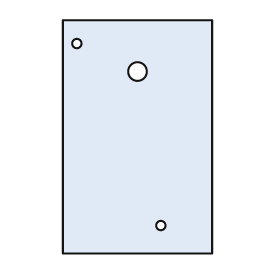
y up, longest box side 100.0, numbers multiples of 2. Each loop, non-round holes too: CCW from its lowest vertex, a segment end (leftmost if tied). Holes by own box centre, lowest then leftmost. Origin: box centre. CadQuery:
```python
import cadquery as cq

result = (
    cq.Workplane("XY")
    .moveTo(-32.0, -50.0)
    .lineTo(32.0, -50.0)
    .lineTo(32.0, 50.0)
    .lineTo(-32.0, 50.0)
    .close()
    .moveTo(10.0, -38.0)
    .circle(2.0)
    .moveTo(0.0, 28.0)
    .circle(4.0)
    .moveTo(-26.0, 40.0)
    .circle(2.0)
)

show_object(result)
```